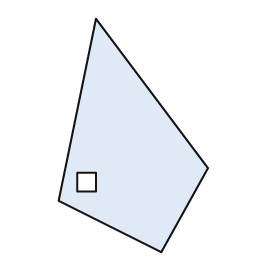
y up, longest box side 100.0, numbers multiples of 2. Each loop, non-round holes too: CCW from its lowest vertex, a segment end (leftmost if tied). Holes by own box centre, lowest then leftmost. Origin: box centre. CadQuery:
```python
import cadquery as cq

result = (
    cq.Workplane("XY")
    .moveTo(12.0, -50.0)
    .lineTo(32.0, -14.0)
    .lineTo(-16.0, 50.0)
    .lineTo(-32.0, -28.0)
    .close()
    .moveTo(-24.0, -24.0)
    .lineTo(-16.0, -24.0)
    .lineTo(-16.0, -16.0)
    .lineTo(-24.0, -16.0)
    .close()
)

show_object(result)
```